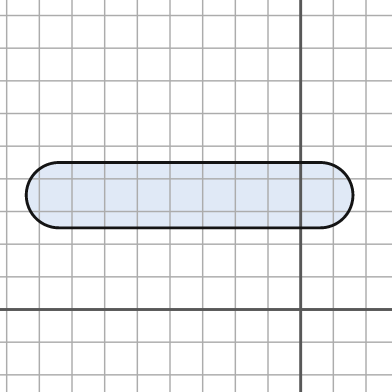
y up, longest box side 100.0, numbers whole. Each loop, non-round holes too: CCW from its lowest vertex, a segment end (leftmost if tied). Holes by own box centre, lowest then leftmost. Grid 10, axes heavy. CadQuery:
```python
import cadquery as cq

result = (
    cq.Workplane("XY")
    .moveTo(-74.0, 25.0)
    .lineTo(6.0, 25.0)
    .threePointArc((16.0, 35.0), (6.0, 45.0))
    .lineTo(-74.0, 45.0)
    .threePointArc((-84.0, 35.0), (-74.0, 25.0))
    .close()
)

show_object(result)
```